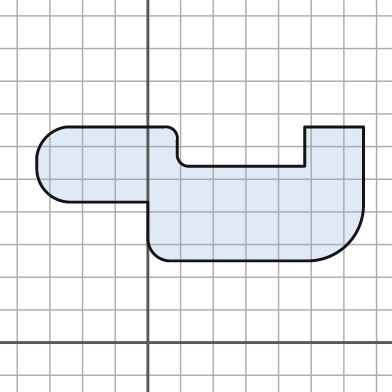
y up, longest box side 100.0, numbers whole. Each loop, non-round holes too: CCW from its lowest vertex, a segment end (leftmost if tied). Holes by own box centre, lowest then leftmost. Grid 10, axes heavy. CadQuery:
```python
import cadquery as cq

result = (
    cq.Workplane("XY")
    .moveTo(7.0, 25.0)
    .lineTo(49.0, 25.0)
    .threePointArc((61.0, 30.0), (66.0, 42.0))
    .lineTo(66.0, 66.0)
    .lineTo(48.0, 66.0)
    .lineTo(48.0, 54.0)
    .lineTo(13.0, 54.0)
    .threePointArc((10.0, 55.0), (9.0, 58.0))
    .lineTo(9.0, 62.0)
    .threePointArc((8.0, 65.0), (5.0, 66.0))
    .lineTo(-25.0, 66.0)
    .threePointArc((-31.0, 63.0), (-34.0, 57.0))
    .lineTo(-34.0, 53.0)
    .threePointArc((-31.0, 46.0), (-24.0, 43.0))
    .lineTo(0.0, 43.0)
    .lineTo(0.0, 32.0)
    .threePointArc((2.0, 27.0), (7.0, 25.0))
    .close()
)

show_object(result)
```